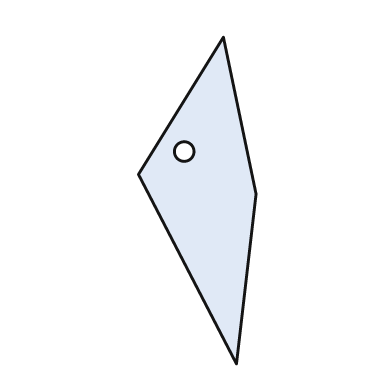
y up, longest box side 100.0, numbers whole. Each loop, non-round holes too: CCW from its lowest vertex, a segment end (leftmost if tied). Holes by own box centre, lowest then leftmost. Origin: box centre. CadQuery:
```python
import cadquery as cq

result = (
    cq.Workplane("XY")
    .moveTo(12.0, -50.0)
    .lineTo(18.0, 2.0)
    .lineTo(8.0, 50.0)
    .lineTo(-18.0, 8.0)
    .close()
    .moveTo(-4.0, 15.0)
    .circle(3.0)
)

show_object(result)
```